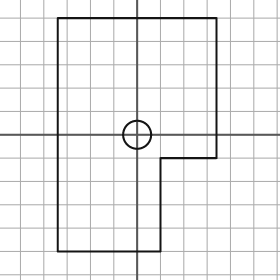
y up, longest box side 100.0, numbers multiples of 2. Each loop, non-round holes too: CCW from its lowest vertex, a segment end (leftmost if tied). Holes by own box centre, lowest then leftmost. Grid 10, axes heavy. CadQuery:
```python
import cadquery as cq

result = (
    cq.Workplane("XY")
    .moveTo(-34.0, -50.0)
    .lineTo(10.0, -50.0)
    .lineTo(10.0, -10.0)
    .lineTo(34.0, -10.0)
    .lineTo(34.0, 50.0)
    .lineTo(-34.0, 50.0)
    .close()
    .moveTo(0.0, 0.0)
    .circle(6.0)
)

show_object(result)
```